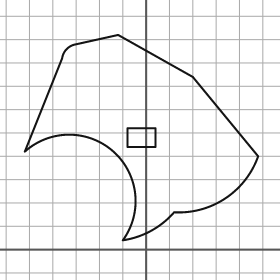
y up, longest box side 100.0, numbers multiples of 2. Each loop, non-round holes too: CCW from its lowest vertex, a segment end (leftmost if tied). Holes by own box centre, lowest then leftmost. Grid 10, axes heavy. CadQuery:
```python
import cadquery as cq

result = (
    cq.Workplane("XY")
    .moveTo(-10.0, 4.0)
    .threePointArc((2.0, 8.0), (12.0, 16.0))
    .threePointArc((34.0, 22.0), (48.0, 40.0))
    .lineTo(20.0, 74.0)
    .lineTo(-12.0, 92.0)
    .lineTo(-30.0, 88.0)
    .threePointArc((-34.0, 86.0), (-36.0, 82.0))
    .lineTo(-52.0, 42.0)
    .threePointArc((-14.0, 42.0), (-10.0, 4.0))
    .close()
    .moveTo(-8.0, 44.0)
    .lineTo(4.0, 44.0)
    .lineTo(4.0, 52.0)
    .lineTo(-8.0, 52.0)
    .close()
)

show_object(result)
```